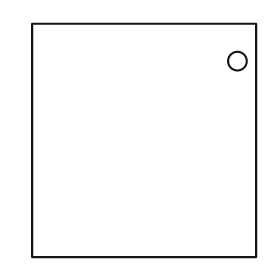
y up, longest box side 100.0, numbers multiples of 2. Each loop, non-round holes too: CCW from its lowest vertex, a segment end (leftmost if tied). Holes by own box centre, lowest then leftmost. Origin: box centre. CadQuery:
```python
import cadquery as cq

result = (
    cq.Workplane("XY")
    .moveTo(-48.0, -50.0)
    .lineTo(48.0, -50.0)
    .lineTo(48.0, 50.0)
    .lineTo(-48.0, 50.0)
    .close()
    .moveTo(40.0, 34.0)
    .circle(4.0)
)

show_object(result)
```